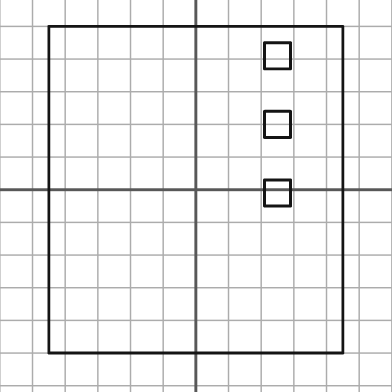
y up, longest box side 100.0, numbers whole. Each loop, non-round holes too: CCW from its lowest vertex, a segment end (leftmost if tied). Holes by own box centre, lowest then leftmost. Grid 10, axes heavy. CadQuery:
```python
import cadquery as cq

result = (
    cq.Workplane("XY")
    .moveTo(-45.0, -50.0)
    .lineTo(45.0, -50.0)
    .lineTo(45.0, 50.0)
    .lineTo(-45.0, 50.0)
    .close()
    .moveTo(21.0, -5.0)
    .lineTo(29.0, -5.0)
    .lineTo(29.0, 3.0)
    .lineTo(21.0, 3.0)
    .close()
    .moveTo(21.0, 16.0)
    .lineTo(29.0, 16.0)
    .lineTo(29.0, 24.0)
    .lineTo(21.0, 24.0)
    .close()
    .moveTo(21.0, 37.0)
    .lineTo(29.0, 37.0)
    .lineTo(29.0, 45.0)
    .lineTo(21.0, 45.0)
    .close()
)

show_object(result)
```